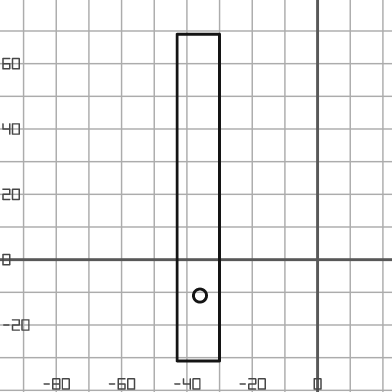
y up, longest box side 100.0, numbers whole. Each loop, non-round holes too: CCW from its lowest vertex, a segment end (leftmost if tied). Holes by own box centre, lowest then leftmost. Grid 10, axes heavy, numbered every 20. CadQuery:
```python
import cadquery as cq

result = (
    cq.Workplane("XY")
    .moveTo(-43.0, -31.0)
    .lineTo(-30.0, -31.0)
    .lineTo(-30.0, 69.0)
    .lineTo(-43.0, 69.0)
    .close()
    .moveTo(-36.0, -11.0)
    .circle(2.0)
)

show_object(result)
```